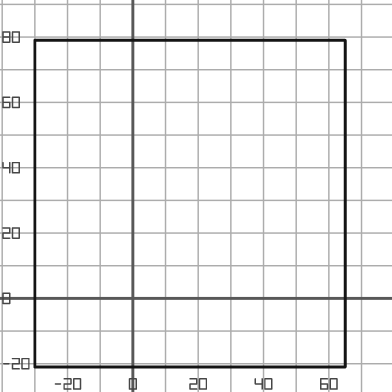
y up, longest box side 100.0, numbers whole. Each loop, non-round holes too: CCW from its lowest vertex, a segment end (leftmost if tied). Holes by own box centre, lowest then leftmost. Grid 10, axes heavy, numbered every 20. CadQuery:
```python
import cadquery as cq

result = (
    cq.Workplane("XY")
    .moveTo(-30.0, -21.0)
    .lineTo(65.0, -21.0)
    .lineTo(65.0, 79.0)
    .lineTo(-30.0, 79.0)
    .close()
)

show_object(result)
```